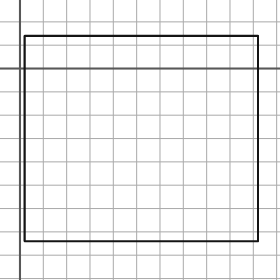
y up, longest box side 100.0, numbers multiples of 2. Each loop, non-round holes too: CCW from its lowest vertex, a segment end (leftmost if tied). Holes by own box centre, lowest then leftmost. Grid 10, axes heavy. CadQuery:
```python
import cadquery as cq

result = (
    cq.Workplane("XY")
    .moveTo(2.0, -74.0)
    .lineTo(102.0, -74.0)
    .lineTo(102.0, 14.0)
    .lineTo(2.0, 14.0)
    .close()
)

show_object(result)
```